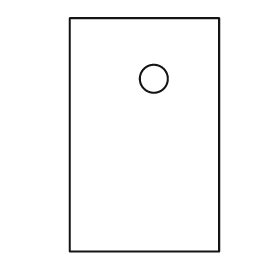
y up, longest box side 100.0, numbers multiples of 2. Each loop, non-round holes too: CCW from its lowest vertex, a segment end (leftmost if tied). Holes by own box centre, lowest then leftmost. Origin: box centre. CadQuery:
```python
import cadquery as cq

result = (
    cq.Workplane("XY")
    .moveTo(-32.0, -50.0)
    .lineTo(32.0, -50.0)
    .lineTo(32.0, 50.0)
    .lineTo(-32.0, 50.0)
    .close()
    .moveTo(4.0, 24.0)
    .circle(6.0)
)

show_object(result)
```